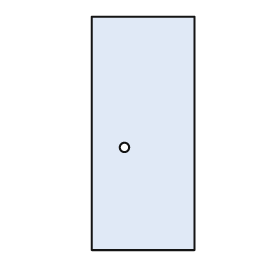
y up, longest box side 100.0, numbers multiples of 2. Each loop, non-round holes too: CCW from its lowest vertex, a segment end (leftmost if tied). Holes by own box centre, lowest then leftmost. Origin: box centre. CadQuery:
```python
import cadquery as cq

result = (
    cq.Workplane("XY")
    .moveTo(-22.0, -50.0)
    .lineTo(22.0, -50.0)
    .lineTo(22.0, 50.0)
    .lineTo(-22.0, 50.0)
    .close()
    .moveTo(-8.0, -6.0)
    .circle(2.0)
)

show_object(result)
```